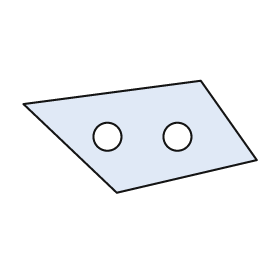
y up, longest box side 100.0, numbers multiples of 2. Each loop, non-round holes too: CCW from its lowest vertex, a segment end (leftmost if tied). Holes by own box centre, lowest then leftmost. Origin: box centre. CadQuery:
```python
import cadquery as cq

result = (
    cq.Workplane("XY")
    .moveTo(-10.0, -24.0)
    .lineTo(50.0, -10.0)
    .lineTo(26.0, 24.0)
    .lineTo(-50.0, 14.0)
    .close()
    .moveTo(-14.0, 0.0)
    .circle(6.0)
    .moveTo(16.0, 0.0)
    .circle(6.0)
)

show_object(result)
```